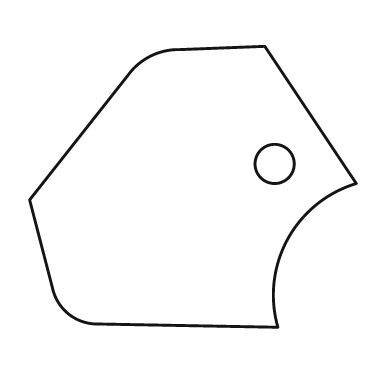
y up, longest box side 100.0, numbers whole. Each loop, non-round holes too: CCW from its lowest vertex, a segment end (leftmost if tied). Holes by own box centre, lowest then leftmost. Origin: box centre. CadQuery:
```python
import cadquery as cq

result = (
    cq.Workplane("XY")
    .moveTo(26.0, -43.0)
    .threePointArc((29.0, -16.0), (50.0, 1.0))
    .lineTo(22.0, 43.0)
    .lineTo(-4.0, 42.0)
    .threePointArc((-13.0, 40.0), (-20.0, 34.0))
    .lineTo(-50.0, -4.0)
    .lineTo(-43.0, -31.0)
    .threePointArc((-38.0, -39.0), (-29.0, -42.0))
    .close()
    .moveTo(25.0, 7.0)
    .circle(6.0)
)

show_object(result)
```